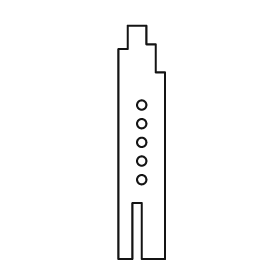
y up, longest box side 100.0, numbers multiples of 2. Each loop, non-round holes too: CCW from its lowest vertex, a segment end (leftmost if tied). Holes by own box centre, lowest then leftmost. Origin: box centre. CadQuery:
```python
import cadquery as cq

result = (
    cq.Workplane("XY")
    .moveTo(-10.0, -50.0)
    .lineTo(-4.0, -50.0)
    .lineTo(-4.0, -26.0)
    .lineTo(0.0, -26.0)
    .lineTo(0.0, -50.0)
    .lineTo(10.0, -50.0)
    .lineTo(10.0, 30.0)
    .lineTo(6.0, 30.0)
    .lineTo(6.0, 42.0)
    .lineTo(2.0, 42.0)
    .lineTo(2.0, 50.0)
    .lineTo(-6.0, 50.0)
    .lineTo(-6.0, 40.0)
    .lineTo(-10.0, 40.0)
    .close()
    .moveTo(0.0, -16.0)
    .circle(2.0)
    .moveTo(0.0, -8.0)
    .circle(2.0)
    .moveTo(0.0, 0.0)
    .circle(2.0)
    .moveTo(0.0, 8.0)
    .circle(2.0)
    .moveTo(0.0, 16.0)
    .circle(2.0)
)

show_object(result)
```